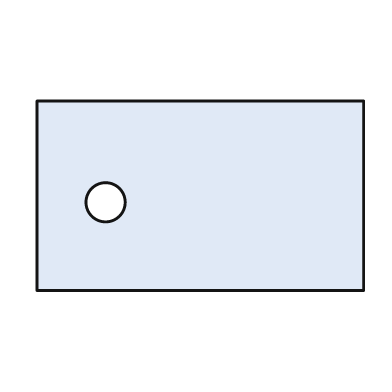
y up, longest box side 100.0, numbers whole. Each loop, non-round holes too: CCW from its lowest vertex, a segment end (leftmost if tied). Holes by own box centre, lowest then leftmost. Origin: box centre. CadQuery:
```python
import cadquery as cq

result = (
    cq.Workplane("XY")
    .moveTo(-50.0, -29.0)
    .lineTo(50.0, -29.0)
    .lineTo(50.0, 29.0)
    .lineTo(-50.0, 29.0)
    .close()
    .moveTo(-29.0, -2.0)
    .circle(6.0)
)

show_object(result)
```